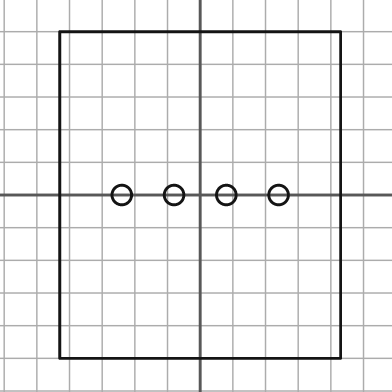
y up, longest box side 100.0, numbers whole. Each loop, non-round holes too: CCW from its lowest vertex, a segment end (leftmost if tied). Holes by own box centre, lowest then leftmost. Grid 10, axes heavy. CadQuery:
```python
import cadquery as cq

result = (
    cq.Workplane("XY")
    .moveTo(-43.0, -50.0)
    .lineTo(43.0, -50.0)
    .lineTo(43.0, 50.0)
    .lineTo(-43.0, 50.0)
    .close()
    .moveTo(-24.0, 0.0)
    .circle(3.0)
    .moveTo(-8.0, 0.0)
    .circle(3.0)
    .moveTo(8.0, 0.0)
    .circle(3.0)
    .moveTo(24.0, 0.0)
    .circle(3.0)
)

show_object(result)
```